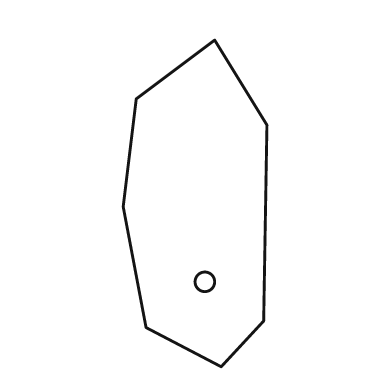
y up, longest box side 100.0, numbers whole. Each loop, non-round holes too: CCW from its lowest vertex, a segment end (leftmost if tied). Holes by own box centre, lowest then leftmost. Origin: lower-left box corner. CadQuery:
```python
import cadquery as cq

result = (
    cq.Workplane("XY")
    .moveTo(30.0, 0.0)
    .lineTo(43.0, 14.0)
    .lineTo(44.0, 74.0)
    .lineTo(28.0, 100.0)
    .lineTo(4.0, 82.0)
    .lineTo(0.0, 49.0)
    .lineTo(7.0, 12.0)
    .close()
    .moveTo(25.0, 26.0)
    .circle(3.0)
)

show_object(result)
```